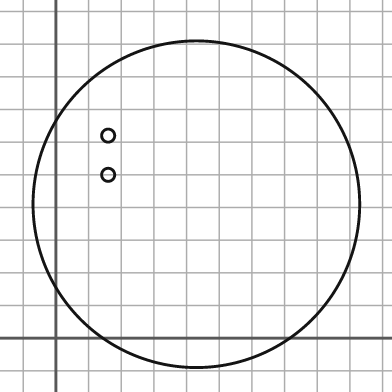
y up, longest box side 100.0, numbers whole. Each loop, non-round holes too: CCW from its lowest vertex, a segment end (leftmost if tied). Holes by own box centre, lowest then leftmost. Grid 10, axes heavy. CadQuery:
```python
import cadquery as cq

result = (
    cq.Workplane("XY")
    .moveTo(43.0, 41.0)
    .circle(50.0)
    .moveTo(16.0, 50.0)
    .circle(2.0)
    .moveTo(16.0, 62.0)
    .circle(2.0)
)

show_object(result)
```